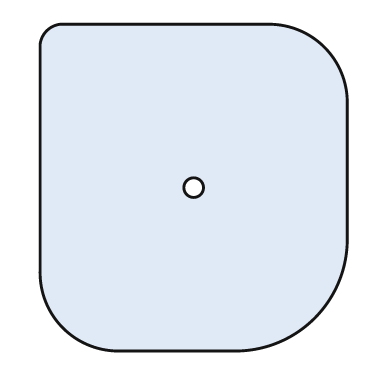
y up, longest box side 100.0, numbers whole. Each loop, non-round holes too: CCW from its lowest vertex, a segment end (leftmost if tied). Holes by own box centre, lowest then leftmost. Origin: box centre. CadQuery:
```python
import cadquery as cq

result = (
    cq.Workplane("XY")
    .moveTo(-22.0, -50.0)
    .lineTo(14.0, -50.0)
    .threePointArc((37.0, -40.0), (47.0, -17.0))
    .lineTo(47.0, 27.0)
    .threePointArc((40.0, 43.0), (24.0, 50.0))
    .lineTo(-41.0, 50.0)
    .threePointArc((-45.0, 48.0), (-47.0, 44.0))
    .lineTo(-47.0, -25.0)
    .threePointArc((-40.0, -43.0), (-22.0, -50.0))
    .close()
    .moveTo(0.0, 0.0)
    .circle(3.0)
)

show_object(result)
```